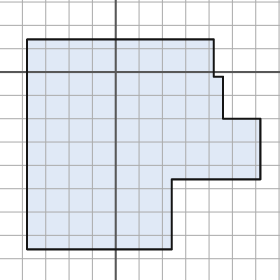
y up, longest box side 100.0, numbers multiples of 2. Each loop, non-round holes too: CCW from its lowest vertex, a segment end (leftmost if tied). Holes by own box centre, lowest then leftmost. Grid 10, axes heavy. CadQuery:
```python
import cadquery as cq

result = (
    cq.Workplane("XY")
    .moveTo(-38.0, -76.0)
    .lineTo(24.0, -76.0)
    .lineTo(24.0, -46.0)
    .lineTo(62.0, -46.0)
    .lineTo(62.0, -20.0)
    .lineTo(46.0, -20.0)
    .lineTo(46.0, -2.0)
    .lineTo(42.0, -2.0)
    .lineTo(42.0, 14.0)
    .lineTo(-38.0, 14.0)
    .close()
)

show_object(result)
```